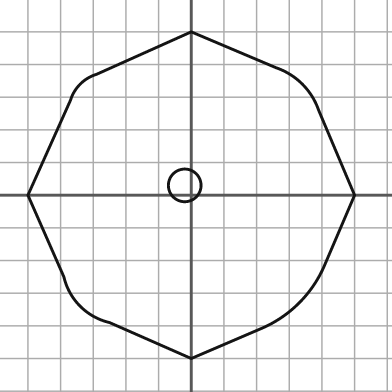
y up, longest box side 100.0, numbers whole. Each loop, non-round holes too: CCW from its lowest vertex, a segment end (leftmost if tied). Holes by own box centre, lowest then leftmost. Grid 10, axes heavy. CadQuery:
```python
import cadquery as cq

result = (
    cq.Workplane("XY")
    .moveTo(0.0, -50.0)
    .lineTo(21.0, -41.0)
    .threePointArc((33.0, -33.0), (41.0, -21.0))
    .lineTo(50.0, 0.0)
    .lineTo(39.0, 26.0)
    .threePointArc((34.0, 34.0), (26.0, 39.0))
    .lineTo(0.0, 50.0)
    .lineTo(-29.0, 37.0)
    .threePointArc((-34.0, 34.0), (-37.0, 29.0))
    .lineTo(-50.0, 0.0)
    .lineTo(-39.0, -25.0)
    .threePointArc((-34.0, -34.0), (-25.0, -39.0))
    .close()
    .moveTo(-2.0, 3.0)
    .circle(5.0)
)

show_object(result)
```